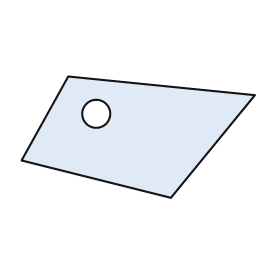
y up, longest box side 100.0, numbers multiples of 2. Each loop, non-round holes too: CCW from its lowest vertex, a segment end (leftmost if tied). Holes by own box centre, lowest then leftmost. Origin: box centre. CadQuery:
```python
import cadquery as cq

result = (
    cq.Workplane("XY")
    .moveTo(14.0, -26.0)
    .lineTo(50.0, 18.0)
    .lineTo(-30.0, 26.0)
    .lineTo(-50.0, -10.0)
    .close()
    .moveTo(-18.0, 10.0)
    .circle(6.0)
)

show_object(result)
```